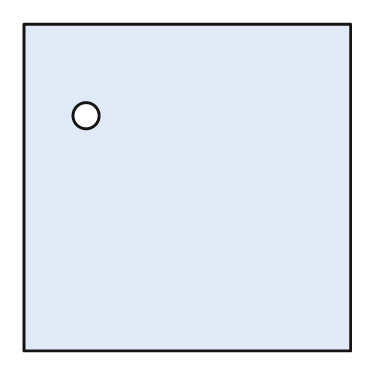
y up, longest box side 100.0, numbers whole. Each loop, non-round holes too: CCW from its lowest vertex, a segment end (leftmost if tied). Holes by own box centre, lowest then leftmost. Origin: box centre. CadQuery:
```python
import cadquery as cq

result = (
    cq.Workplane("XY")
    .moveTo(-50.0, -50.0)
    .lineTo(50.0, -50.0)
    .lineTo(50.0, 50.0)
    .lineTo(-50.0, 50.0)
    .close()
    .moveTo(-31.0, 22.0)
    .circle(4.0)
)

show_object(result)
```